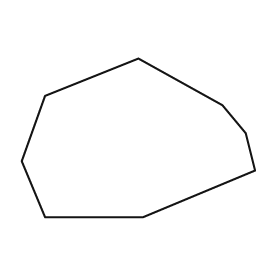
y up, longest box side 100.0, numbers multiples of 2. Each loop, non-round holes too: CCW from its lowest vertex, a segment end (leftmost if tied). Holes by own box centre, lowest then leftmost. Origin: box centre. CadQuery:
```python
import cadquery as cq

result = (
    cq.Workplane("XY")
    .moveTo(-40.0, -34.0)
    .lineTo(2.0, -34.0)
    .lineTo(50.0, -14.0)
    .lineTo(46.0, 2.0)
    .lineTo(36.0, 14.0)
    .lineTo(0.0, 34.0)
    .lineTo(-40.0, 18.0)
    .lineTo(-50.0, -10.0)
    .close()
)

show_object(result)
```